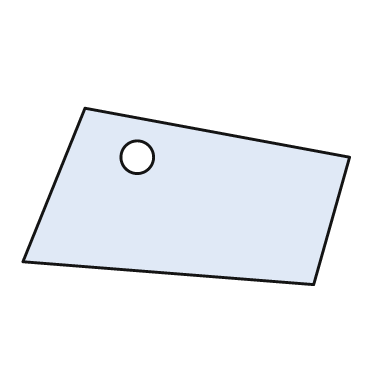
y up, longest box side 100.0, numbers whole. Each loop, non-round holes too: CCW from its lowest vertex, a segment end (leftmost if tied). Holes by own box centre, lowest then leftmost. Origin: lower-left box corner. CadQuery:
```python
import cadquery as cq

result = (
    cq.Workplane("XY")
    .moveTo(89.0, 0.0)
    .lineTo(100.0, 39.0)
    .lineTo(19.0, 54.0)
    .lineTo(0.0, 7.0)
    .close()
    .moveTo(35.0, 39.0)
    .circle(5.0)
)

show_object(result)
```